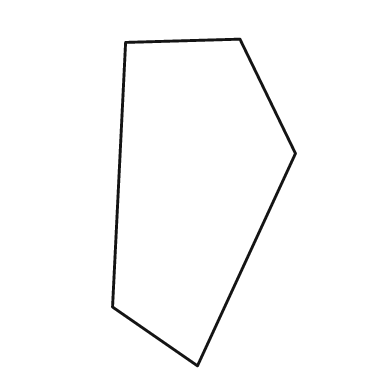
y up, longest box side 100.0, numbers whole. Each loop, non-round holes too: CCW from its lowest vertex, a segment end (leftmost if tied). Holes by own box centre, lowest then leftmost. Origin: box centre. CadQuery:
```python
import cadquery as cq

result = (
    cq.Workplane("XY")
    .moveTo(-2.0, -50.0)
    .lineTo(28.0, 15.0)
    .lineTo(11.0, 50.0)
    .lineTo(-24.0, 49.0)
    .lineTo(-28.0, -32.0)
    .close()
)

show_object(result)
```